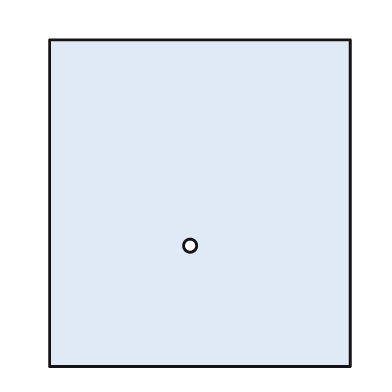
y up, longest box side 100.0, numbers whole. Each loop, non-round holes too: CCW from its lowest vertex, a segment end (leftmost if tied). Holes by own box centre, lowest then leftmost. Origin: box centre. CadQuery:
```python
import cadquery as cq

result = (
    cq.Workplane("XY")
    .moveTo(-46.0, -50.0)
    .lineTo(46.0, -50.0)
    .lineTo(46.0, 50.0)
    .lineTo(-46.0, 50.0)
    .close()
    .moveTo(-3.0, -13.0)
    .circle(2.0)
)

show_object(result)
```